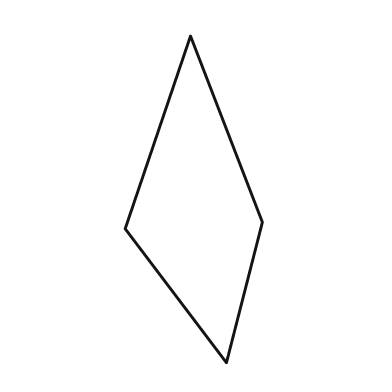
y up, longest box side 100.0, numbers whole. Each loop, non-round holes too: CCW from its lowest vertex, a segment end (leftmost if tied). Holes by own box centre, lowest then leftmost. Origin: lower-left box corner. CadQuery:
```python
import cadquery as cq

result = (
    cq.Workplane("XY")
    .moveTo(31.0, 0.0)
    .lineTo(42.0, 43.0)
    .lineTo(20.0, 100.0)
    .lineTo(0.0, 41.0)
    .close()
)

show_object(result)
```